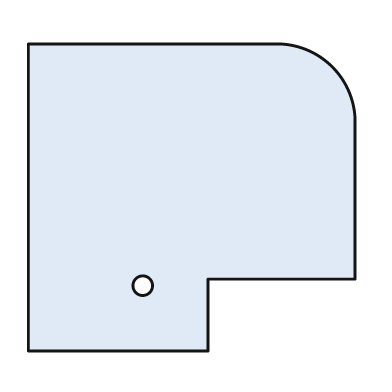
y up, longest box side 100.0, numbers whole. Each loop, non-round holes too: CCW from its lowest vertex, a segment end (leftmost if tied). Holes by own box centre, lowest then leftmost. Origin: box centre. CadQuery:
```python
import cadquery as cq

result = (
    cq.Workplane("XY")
    .moveTo(-50.0, -47.0)
    .lineTo(5.0, -47.0)
    .lineTo(5.0, -25.0)
    .lineTo(50.0, -25.0)
    .lineTo(50.0, 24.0)
    .threePointArc((43.0, 40.0), (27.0, 47.0))
    .lineTo(-50.0, 47.0)
    .close()
    .moveTo(-15.0, -27.0)
    .circle(3.0)
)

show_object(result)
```